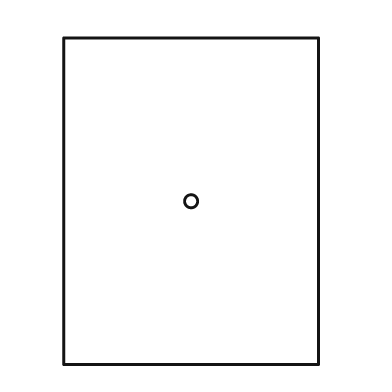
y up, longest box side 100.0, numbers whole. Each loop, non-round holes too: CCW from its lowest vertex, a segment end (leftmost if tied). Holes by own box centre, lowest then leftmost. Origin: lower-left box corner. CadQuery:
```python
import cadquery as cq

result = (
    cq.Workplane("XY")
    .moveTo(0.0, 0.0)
    .lineTo(78.0, 0.0)
    .lineTo(78.0, 100.0)
    .lineTo(0.0, 100.0)
    .close()
    .moveTo(39.0, 50.0)
    .circle(2.0)
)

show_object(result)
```